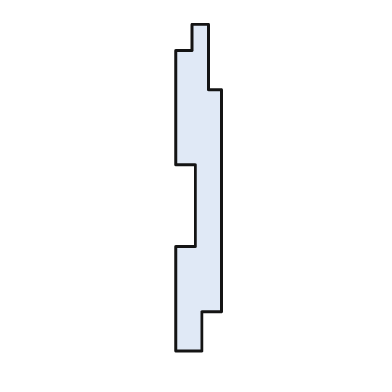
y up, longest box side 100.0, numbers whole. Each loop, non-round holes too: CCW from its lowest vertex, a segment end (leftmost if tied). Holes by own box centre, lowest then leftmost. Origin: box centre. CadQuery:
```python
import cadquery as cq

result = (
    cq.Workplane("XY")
    .moveTo(-7.0, -50.0)
    .lineTo(1.0, -50.0)
    .lineTo(1.0, -38.0)
    .lineTo(7.0, -38.0)
    .lineTo(7.0, 30.0)
    .lineTo(3.0, 30.0)
    .lineTo(3.0, 50.0)
    .lineTo(-2.0, 50.0)
    .lineTo(-2.0, 42.0)
    .lineTo(-7.0, 42.0)
    .lineTo(-7.0, 7.0)
    .lineTo(-1.0, 7.0)
    .lineTo(-1.0, -18.0)
    .lineTo(-7.0, -18.0)
    .close()
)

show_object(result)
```